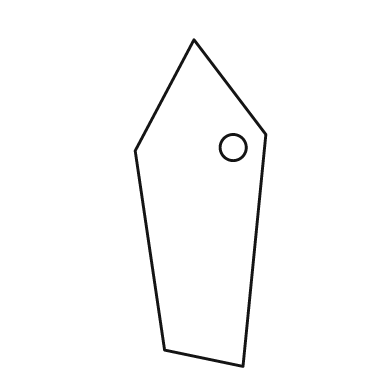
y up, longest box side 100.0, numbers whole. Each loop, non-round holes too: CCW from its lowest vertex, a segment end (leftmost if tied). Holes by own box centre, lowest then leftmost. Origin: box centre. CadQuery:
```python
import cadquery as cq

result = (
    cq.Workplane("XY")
    .moveTo(13.0, -50.0)
    .lineTo(20.0, 21.0)
    .lineTo(-2.0, 50.0)
    .lineTo(-20.0, 16.0)
    .lineTo(-11.0, -45.0)
    .close()
    .moveTo(10.0, 17.0)
    .circle(4.0)
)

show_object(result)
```